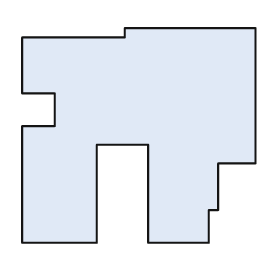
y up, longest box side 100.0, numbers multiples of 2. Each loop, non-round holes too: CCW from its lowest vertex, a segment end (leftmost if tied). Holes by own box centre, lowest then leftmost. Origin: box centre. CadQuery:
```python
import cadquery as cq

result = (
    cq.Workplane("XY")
    .moveTo(-50.0, -46.0)
    .lineTo(-18.0, -46.0)
    .lineTo(-18.0, -4.0)
    .lineTo(4.0, -4.0)
    .lineTo(4.0, -46.0)
    .lineTo(30.0, -46.0)
    .lineTo(30.0, -32.0)
    .lineTo(34.0, -32.0)
    .lineTo(34.0, -12.0)
    .lineTo(50.0, -12.0)
    .lineTo(50.0, 46.0)
    .lineTo(-6.0, 46.0)
    .lineTo(-6.0, 42.0)
    .lineTo(-50.0, 42.0)
    .lineTo(-50.0, 18.0)
    .lineTo(-36.0, 18.0)
    .lineTo(-36.0, 4.0)
    .lineTo(-50.0, 4.0)
    .close()
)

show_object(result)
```